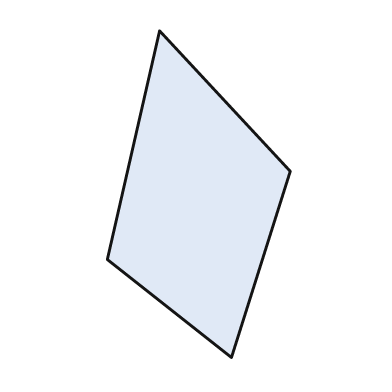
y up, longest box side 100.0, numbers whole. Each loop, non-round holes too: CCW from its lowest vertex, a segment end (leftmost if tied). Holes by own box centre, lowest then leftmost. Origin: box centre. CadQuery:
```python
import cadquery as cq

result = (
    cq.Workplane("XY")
    .moveTo(10.0, -50.0)
    .lineTo(28.0, 7.0)
    .lineTo(-12.0, 50.0)
    .lineTo(-28.0, -20.0)
    .close()
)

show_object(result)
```